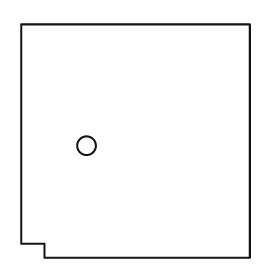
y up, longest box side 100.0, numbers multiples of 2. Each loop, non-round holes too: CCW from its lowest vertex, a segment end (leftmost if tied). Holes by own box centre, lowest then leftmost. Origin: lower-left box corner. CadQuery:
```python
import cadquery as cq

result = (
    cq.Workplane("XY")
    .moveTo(10.0, 0.0)
    .lineTo(98.0, 0.0)
    .lineTo(98.0, 100.0)
    .lineTo(0.0, 100.0)
    .lineTo(0.0, 6.0)
    .lineTo(10.0, 6.0)
    .close()
    .moveTo(28.0, 48.0)
    .circle(4.0)
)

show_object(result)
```